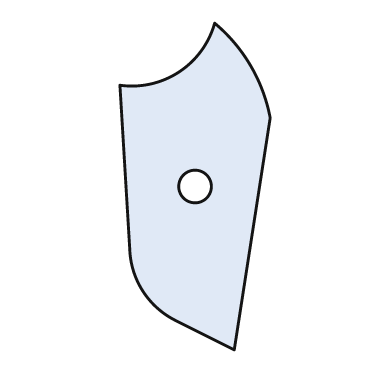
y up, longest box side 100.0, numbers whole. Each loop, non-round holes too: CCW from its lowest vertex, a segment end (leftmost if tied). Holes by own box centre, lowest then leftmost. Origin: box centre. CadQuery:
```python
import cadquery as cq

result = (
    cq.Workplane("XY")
    .moveTo(12.0, -50.0)
    .lineTo(23.0, 21.0)
    .threePointArc((17.0, 37.0), (6.0, 50.0))
    .threePointArc((-5.0, 35.0), (-23.0, 31.0))
    .lineTo(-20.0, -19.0)
    .threePointArc((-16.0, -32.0), (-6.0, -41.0))
    .close()
    .moveTo(0.0, 0.0)
    .circle(5.0)
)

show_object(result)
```